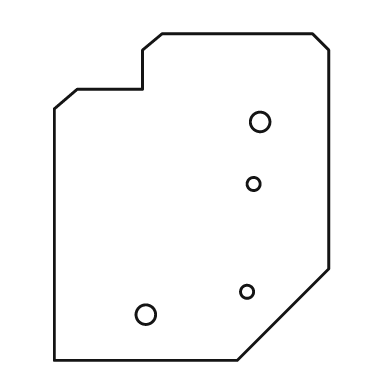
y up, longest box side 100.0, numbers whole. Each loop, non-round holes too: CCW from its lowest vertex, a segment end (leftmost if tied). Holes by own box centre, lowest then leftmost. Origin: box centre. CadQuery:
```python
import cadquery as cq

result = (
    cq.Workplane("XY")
    .moveTo(-42.0, -50.0)
    .lineTo(14.0, -50.0)
    .lineTo(42.0, -22.0)
    .lineTo(42.0, 45.0)
    .lineTo(37.0, 50.0)
    .lineTo(-9.0, 50.0)
    .lineTo(-15.0, 45.0)
    .lineTo(-15.0, 33.0)
    .lineTo(-35.0, 33.0)
    .lineTo(-42.0, 27.0)
    .close()
    .moveTo(-14.0, -36.0)
    .circle(3.0)
    .moveTo(17.0, -29.0)
    .circle(2.0)
    .moveTo(19.0, 4.0)
    .circle(2.0)
    .moveTo(21.0, 23.0)
    .circle(3.0)
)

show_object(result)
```